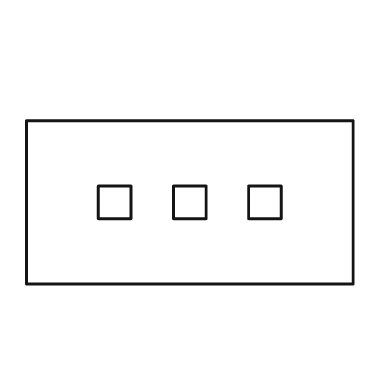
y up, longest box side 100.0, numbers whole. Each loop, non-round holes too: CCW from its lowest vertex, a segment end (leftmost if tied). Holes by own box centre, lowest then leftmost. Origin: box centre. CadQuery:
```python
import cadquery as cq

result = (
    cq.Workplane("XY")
    .moveTo(-50.0, -25.0)
    .lineTo(50.0, -25.0)
    .lineTo(50.0, 25.0)
    .lineTo(-50.0, 25.0)
    .close()
    .moveTo(-28.0, -5.0)
    .lineTo(-18.0, -5.0)
    .lineTo(-18.0, 5.0)
    .lineTo(-28.0, 5.0)
    .close()
    .moveTo(-5.0, -5.0)
    .lineTo(5.0, -5.0)
    .lineTo(5.0, 5.0)
    .lineTo(-5.0, 5.0)
    .close()
    .moveTo(18.0, -5.0)
    .lineTo(28.0, -5.0)
    .lineTo(28.0, 5.0)
    .lineTo(18.0, 5.0)
    .close()
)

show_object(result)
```